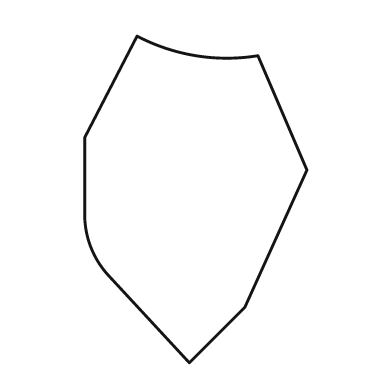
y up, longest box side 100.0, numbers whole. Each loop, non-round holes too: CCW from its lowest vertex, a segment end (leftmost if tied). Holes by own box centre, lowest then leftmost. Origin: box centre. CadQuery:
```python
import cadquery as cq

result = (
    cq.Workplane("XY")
    .moveTo(-2.0, -50.0)
    .lineTo(15.0, -33.0)
    .lineTo(34.0, 9.0)
    .lineTo(19.0, 44.0)
    .threePointArc((0.0, 44.0), (-18.0, 50.0))
    .lineTo(-34.0, 19.0)
    .lineTo(-34.0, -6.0)
    .threePointArc((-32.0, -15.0), (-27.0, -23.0))
    .close()
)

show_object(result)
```